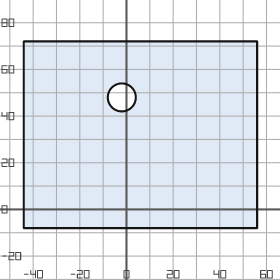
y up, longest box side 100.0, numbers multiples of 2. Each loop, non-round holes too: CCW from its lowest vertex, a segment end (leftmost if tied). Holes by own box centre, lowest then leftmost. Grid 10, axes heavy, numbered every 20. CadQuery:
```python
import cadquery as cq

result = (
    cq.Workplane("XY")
    .moveTo(-44.0, -8.0)
    .lineTo(56.0, -8.0)
    .lineTo(56.0, 72.0)
    .lineTo(-44.0, 72.0)
    .close()
    .moveTo(-2.0, 48.0)
    .circle(6.0)
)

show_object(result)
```